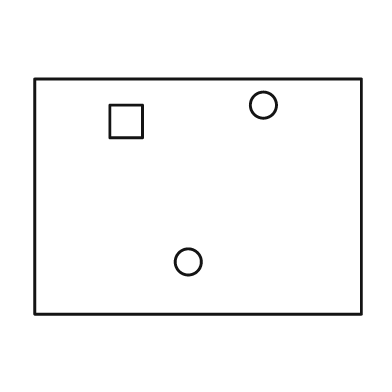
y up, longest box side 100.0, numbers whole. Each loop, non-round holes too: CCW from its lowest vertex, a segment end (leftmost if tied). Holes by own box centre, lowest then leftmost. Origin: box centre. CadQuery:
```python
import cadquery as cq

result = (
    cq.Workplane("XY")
    .moveTo(-50.0, -36.0)
    .lineTo(50.0, -36.0)
    .lineTo(50.0, 36.0)
    .lineTo(-50.0, 36.0)
    .close()
    .moveTo(-3.0, -20.0)
    .circle(4.0)
    .moveTo(-27.0, 18.0)
    .lineTo(-17.0, 18.0)
    .lineTo(-17.0, 28.0)
    .lineTo(-27.0, 28.0)
    .close()
    .moveTo(20.0, 28.0)
    .circle(4.0)
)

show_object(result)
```